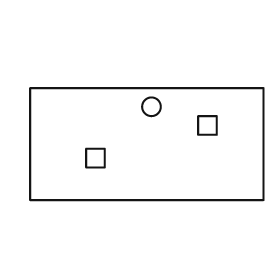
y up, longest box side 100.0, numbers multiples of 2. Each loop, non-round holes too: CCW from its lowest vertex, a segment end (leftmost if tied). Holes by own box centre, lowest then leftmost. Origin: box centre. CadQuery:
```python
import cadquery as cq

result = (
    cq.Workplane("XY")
    .moveTo(-50.0, -24.0)
    .lineTo(50.0, -24.0)
    .lineTo(50.0, 24.0)
    .lineTo(-50.0, 24.0)
    .close()
    .moveTo(-26.0, -10.0)
    .lineTo(-18.0, -10.0)
    .lineTo(-18.0, -2.0)
    .lineTo(-26.0, -2.0)
    .close()
    .moveTo(22.0, 4.0)
    .lineTo(30.0, 4.0)
    .lineTo(30.0, 12.0)
    .lineTo(22.0, 12.0)
    .close()
    .moveTo(2.0, 16.0)
    .circle(4.0)
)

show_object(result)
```